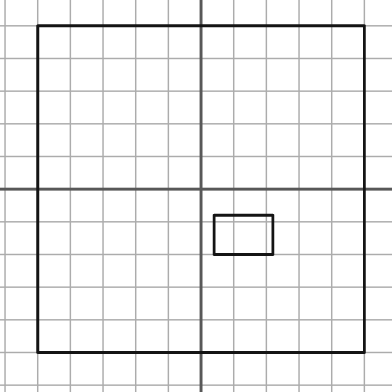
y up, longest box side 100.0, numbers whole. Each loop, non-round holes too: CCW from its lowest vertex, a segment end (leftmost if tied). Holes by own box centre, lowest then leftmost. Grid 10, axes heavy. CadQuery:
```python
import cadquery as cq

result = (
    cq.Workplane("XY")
    .moveTo(-50.0, -50.0)
    .lineTo(50.0, -50.0)
    .lineTo(50.0, 50.0)
    .lineTo(-50.0, 50.0)
    .close()
    .moveTo(4.0, -20.0)
    .lineTo(22.0, -20.0)
    .lineTo(22.0, -8.0)
    .lineTo(4.0, -8.0)
    .close()
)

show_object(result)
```